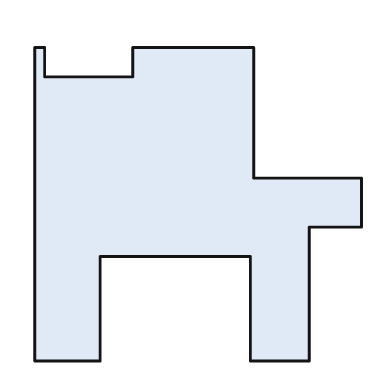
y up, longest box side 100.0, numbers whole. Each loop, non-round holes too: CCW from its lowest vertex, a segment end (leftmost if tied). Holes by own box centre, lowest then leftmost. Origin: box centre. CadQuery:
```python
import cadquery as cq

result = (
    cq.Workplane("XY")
    .moveTo(-50.0, -48.0)
    .lineTo(-30.0, -48.0)
    .lineTo(-30.0, -16.0)
    .lineTo(16.0, -16.0)
    .lineTo(16.0, -48.0)
    .lineTo(34.0, -48.0)
    .lineTo(34.0, -7.0)
    .lineTo(50.0, -7.0)
    .lineTo(50.0, 8.0)
    .lineTo(17.0, 8.0)
    .lineTo(17.0, 48.0)
    .lineTo(-20.0, 48.0)
    .lineTo(-20.0, 39.0)
    .lineTo(-47.0, 39.0)
    .lineTo(-47.0, 48.0)
    .lineTo(-50.0, 48.0)
    .close()
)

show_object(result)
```